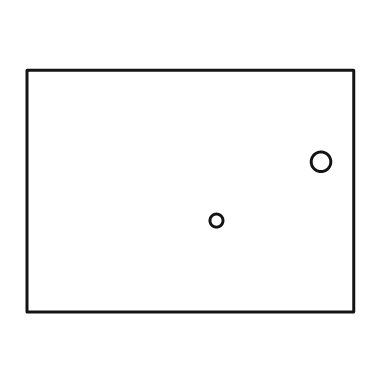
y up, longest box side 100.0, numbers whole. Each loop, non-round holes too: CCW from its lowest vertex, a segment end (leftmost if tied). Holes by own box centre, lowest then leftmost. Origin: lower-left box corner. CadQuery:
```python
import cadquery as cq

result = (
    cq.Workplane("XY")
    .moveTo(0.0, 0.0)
    .lineTo(100.0, 0.0)
    .lineTo(100.0, 74.0)
    .lineTo(0.0, 74.0)
    .close()
    .moveTo(58.0, 28.0)
    .circle(2.0)
    .moveTo(90.0, 46.0)
    .circle(3.0)
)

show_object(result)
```